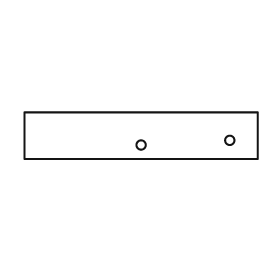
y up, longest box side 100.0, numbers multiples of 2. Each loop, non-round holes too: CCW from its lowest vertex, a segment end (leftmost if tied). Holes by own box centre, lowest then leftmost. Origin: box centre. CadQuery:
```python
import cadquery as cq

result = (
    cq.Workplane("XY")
    .moveTo(-50.0, -10.0)
    .lineTo(50.0, -10.0)
    .lineTo(50.0, 10.0)
    .lineTo(-50.0, 10.0)
    .close()
    .moveTo(0.0, -4.0)
    .circle(2.0)
    .moveTo(38.0, -2.0)
    .circle(2.0)
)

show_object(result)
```